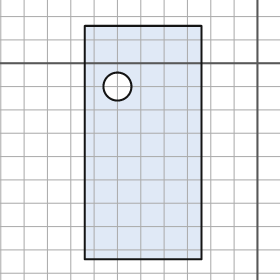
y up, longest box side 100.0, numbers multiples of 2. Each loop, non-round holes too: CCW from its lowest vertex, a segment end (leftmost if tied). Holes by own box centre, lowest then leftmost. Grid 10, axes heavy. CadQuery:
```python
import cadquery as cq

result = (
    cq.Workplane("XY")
    .moveTo(-74.0, -84.0)
    .lineTo(-24.0, -84.0)
    .lineTo(-24.0, 16.0)
    .lineTo(-74.0, 16.0)
    .close()
    .moveTo(-60.0, -10.0)
    .circle(6.0)
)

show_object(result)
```